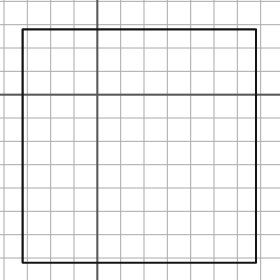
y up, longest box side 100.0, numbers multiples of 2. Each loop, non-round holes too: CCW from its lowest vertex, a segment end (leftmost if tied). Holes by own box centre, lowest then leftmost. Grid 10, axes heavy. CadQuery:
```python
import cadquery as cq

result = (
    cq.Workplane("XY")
    .moveTo(-32.0, -72.0)
    .lineTo(68.0, -72.0)
    .lineTo(68.0, 28.0)
    .lineTo(-32.0, 28.0)
    .close()
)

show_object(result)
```